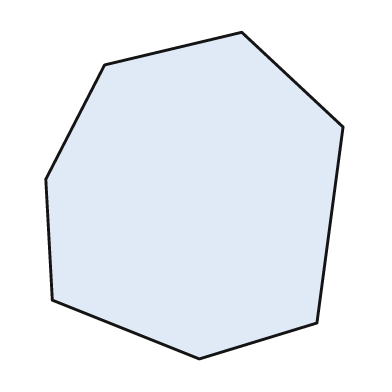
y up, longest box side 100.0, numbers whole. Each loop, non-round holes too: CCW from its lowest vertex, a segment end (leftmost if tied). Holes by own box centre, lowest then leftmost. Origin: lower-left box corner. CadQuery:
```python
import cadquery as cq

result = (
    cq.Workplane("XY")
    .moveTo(47.0, 0.0)
    .lineTo(83.0, 11.0)
    .lineTo(91.0, 71.0)
    .lineTo(60.0, 100.0)
    .lineTo(18.0, 90.0)
    .lineTo(0.0, 55.0)
    .lineTo(2.0, 18.0)
    .close()
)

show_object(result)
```